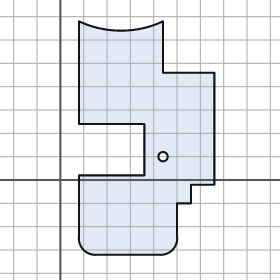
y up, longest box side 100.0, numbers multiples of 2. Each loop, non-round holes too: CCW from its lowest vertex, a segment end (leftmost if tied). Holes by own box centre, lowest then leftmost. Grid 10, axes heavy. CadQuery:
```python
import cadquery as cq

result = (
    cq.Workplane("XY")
    .moveTo(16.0, -32.0)
    .lineTo(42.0, -32.0)
    .threePointArc((48.0, -30.0), (50.0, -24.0))
    .lineTo(50.0, -10.0)
    .lineTo(56.0, -10.0)
    .lineTo(56.0, -2.0)
    .lineTo(66.0, -2.0)
    .lineTo(66.0, 46.0)
    .lineTo(44.0, 46.0)
    .lineTo(44.0, 68.0)
    .threePointArc((26.0, 64.0), (8.0, 68.0))
    .lineTo(8.0, 24.0)
    .lineTo(36.0, 24.0)
    .lineTo(36.0, 2.0)
    .lineTo(8.0, 2.0)
    .lineTo(8.0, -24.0)
    .threePointArc((10.0, -30.0), (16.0, -32.0))
    .close()
    .moveTo(44.0, 10.0)
    .circle(2.0)
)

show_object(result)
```